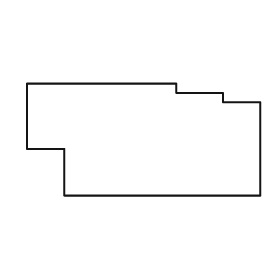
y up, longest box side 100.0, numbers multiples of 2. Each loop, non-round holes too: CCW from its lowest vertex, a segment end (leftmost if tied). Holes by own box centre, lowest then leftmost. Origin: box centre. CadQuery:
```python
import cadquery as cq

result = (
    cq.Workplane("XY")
    .moveTo(-34.0, -24.0)
    .lineTo(50.0, -24.0)
    .lineTo(50.0, 16.0)
    .lineTo(34.0, 16.0)
    .lineTo(34.0, 20.0)
    .lineTo(14.0, 20.0)
    .lineTo(14.0, 24.0)
    .lineTo(-50.0, 24.0)
    .lineTo(-50.0, -4.0)
    .lineTo(-34.0, -4.0)
    .close()
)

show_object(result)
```